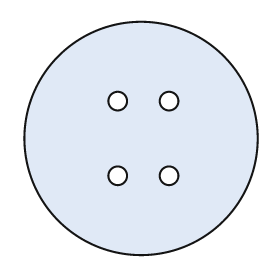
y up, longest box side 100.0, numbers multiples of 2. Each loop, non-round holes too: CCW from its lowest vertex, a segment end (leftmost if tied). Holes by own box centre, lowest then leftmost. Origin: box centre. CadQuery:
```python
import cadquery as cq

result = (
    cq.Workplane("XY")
    .moveTo(0.0, 0.0)
    .circle(50.0)
    .moveTo(-10.0, -16.0)
    .circle(4.0)
    .moveTo(12.0, -16.0)
    .circle(4.0)
    .moveTo(-10.0, 16.0)
    .circle(4.0)
    .moveTo(12.0, 16.0)
    .circle(4.0)
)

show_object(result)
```